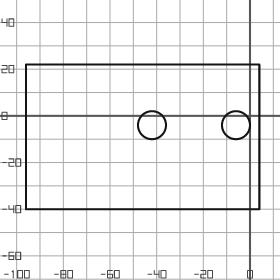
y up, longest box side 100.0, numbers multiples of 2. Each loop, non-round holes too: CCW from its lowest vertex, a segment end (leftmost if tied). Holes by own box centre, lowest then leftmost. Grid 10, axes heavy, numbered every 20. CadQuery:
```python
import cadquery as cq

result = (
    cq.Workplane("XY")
    .moveTo(-96.0, -40.0)
    .lineTo(4.0, -40.0)
    .lineTo(4.0, 22.0)
    .lineTo(-96.0, 22.0)
    .close()
    .moveTo(-42.0, -4.0)
    .circle(6.0)
    .moveTo(-6.0, -4.0)
    .circle(6.0)
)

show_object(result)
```